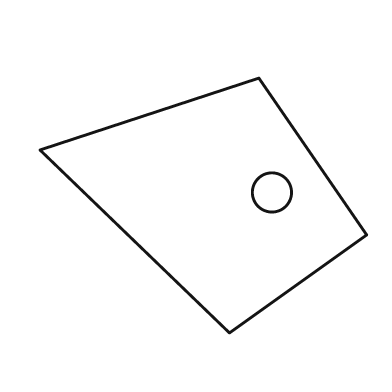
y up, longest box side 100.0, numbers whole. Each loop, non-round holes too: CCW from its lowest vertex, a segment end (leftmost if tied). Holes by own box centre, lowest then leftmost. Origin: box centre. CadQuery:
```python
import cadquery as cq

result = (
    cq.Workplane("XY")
    .moveTo(8.0, -39.0)
    .lineTo(50.0, -9.0)
    .lineTo(17.0, 39.0)
    .lineTo(-50.0, 17.0)
    .close()
    .moveTo(21.0, 4.0)
    .circle(6.0)
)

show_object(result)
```